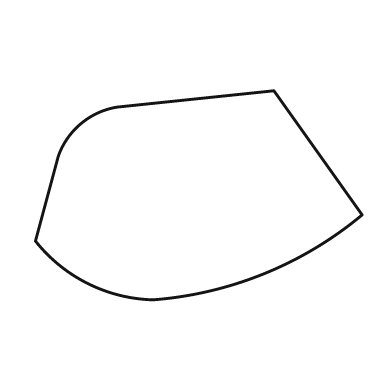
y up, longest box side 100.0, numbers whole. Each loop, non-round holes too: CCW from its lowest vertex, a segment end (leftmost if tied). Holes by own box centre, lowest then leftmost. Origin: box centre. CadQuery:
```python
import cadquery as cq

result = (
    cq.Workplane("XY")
    .moveTo(-14.0, -32.0)
    .threePointArc((20.0, -24.0), (50.0, -6.0))
    .lineTo(23.0, 32.0)
    .lineTo(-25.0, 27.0)
    .threePointArc((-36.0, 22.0), (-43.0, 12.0))
    .lineTo(-50.0, -14.0)
    .threePointArc((-34.0, -27.0), (-14.0, -32.0))
    .close()
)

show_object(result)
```